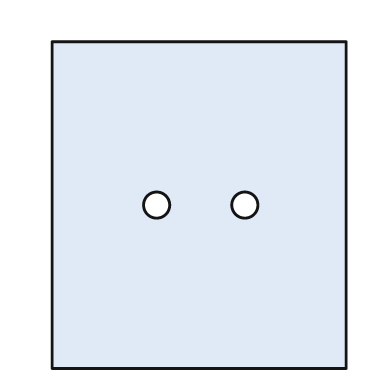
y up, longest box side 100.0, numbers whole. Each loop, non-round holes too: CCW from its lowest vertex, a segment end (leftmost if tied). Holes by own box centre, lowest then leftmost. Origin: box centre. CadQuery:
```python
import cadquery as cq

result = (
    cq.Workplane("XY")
    .moveTo(-45.0, -50.0)
    .lineTo(45.0, -50.0)
    .lineTo(45.0, 50.0)
    .lineTo(-45.0, 50.0)
    .close()
    .moveTo(-13.0, 0.0)
    .circle(4.0)
    .moveTo(14.0, 0.0)
    .circle(4.0)
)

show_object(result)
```